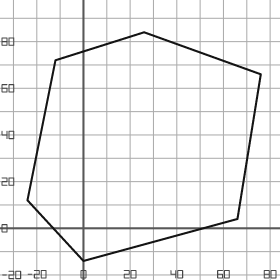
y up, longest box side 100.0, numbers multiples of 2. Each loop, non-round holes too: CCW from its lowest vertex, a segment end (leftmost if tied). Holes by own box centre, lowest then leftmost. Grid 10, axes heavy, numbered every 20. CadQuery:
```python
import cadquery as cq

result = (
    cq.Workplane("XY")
    .moveTo(0.0, -14.0)
    .lineTo(66.0, 4.0)
    .lineTo(76.0, 66.0)
    .lineTo(26.0, 84.0)
    .lineTo(-12.0, 72.0)
    .lineTo(-24.0, 12.0)
    .close()
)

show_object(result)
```